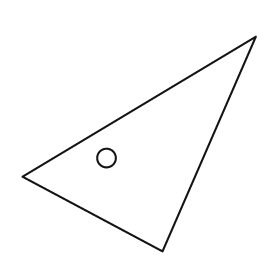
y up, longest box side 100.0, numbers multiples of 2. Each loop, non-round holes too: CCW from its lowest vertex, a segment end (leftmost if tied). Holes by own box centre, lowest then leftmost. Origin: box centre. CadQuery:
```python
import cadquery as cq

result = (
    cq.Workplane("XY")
    .moveTo(10.0, -46.0)
    .lineTo(50.0, 46.0)
    .lineTo(-50.0, -14.0)
    .close()
    .moveTo(-14.0, -6.0)
    .circle(4.0)
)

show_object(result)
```